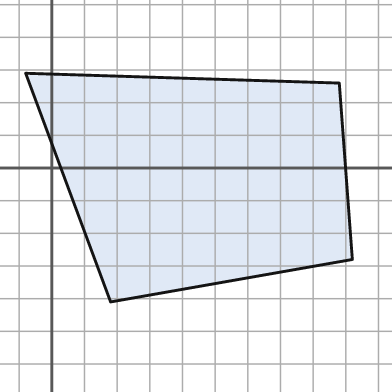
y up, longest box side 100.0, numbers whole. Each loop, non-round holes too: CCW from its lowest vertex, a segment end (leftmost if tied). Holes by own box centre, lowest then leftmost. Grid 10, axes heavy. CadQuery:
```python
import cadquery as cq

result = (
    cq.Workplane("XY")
    .moveTo(18.0, -41.0)
    .lineTo(92.0, -28.0)
    .lineTo(88.0, 26.0)
    .lineTo(-8.0, 29.0)
    .close()
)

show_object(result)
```